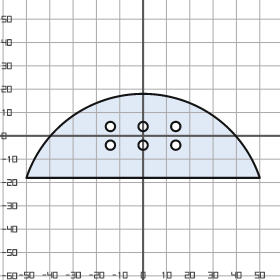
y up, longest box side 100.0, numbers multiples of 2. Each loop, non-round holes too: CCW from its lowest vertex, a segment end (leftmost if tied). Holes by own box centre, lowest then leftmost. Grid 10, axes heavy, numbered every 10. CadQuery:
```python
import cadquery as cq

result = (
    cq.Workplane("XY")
    .moveTo(-50.0, -18.0)
    .lineTo(50.0, -18.0)
    .threePointArc((0.0, 18.0), (-50.0, -18.0))
    .close()
    .moveTo(-14.0, -4.0)
    .circle(2.0)
    .moveTo(0.0, -4.0)
    .circle(2.0)
    .moveTo(14.0, -4.0)
    .circle(2.0)
    .moveTo(-14.0, 4.0)
    .circle(2.0)
    .moveTo(0.0, 4.0)
    .circle(2.0)
    .moveTo(14.0, 4.0)
    .circle(2.0)
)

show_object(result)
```